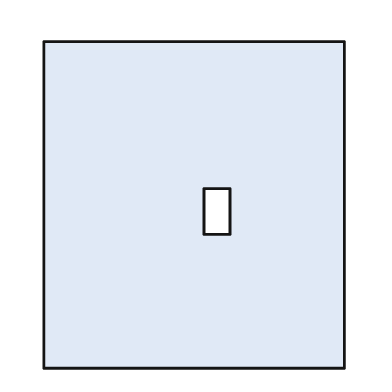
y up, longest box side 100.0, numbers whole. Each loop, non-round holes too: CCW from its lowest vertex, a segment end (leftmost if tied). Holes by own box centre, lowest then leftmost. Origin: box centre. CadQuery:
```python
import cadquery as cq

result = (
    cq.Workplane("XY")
    .moveTo(-46.0, -50.0)
    .lineTo(46.0, -50.0)
    .lineTo(46.0, 50.0)
    .lineTo(-46.0, 50.0)
    .close()
    .moveTo(3.0, -9.0)
    .lineTo(11.0, -9.0)
    .lineTo(11.0, 5.0)
    .lineTo(3.0, 5.0)
    .close()
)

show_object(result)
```